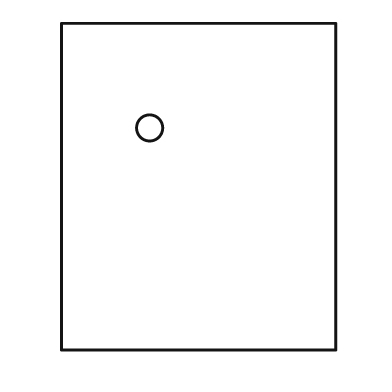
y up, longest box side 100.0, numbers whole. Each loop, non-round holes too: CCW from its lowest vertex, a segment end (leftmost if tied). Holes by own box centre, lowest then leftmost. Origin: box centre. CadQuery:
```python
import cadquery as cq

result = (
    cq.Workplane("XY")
    .moveTo(-42.0, -50.0)
    .lineTo(42.0, -50.0)
    .lineTo(42.0, 50.0)
    .lineTo(-42.0, 50.0)
    .close()
    .moveTo(-15.0, 18.0)
    .circle(4.0)
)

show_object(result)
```